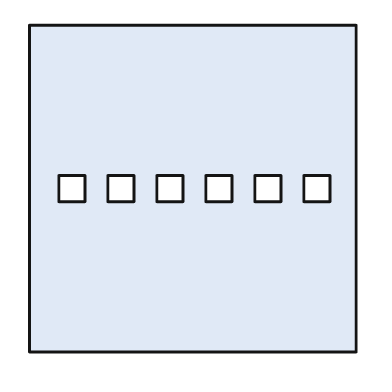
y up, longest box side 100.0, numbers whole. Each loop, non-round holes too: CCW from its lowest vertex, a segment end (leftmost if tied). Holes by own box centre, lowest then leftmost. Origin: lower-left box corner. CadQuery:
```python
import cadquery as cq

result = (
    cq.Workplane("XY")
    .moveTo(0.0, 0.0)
    .lineTo(100.0, 0.0)
    .lineTo(100.0, 100.0)
    .lineTo(0.0, 100.0)
    .close()
    .moveTo(9.0, 46.0)
    .lineTo(17.0, 46.0)
    .lineTo(17.0, 54.0)
    .lineTo(9.0, 54.0)
    .close()
    .moveTo(24.0, 46.0)
    .lineTo(32.0, 46.0)
    .lineTo(32.0, 54.0)
    .lineTo(24.0, 54.0)
    .close()
    .moveTo(39.0, 46.0)
    .lineTo(47.0, 46.0)
    .lineTo(47.0, 54.0)
    .lineTo(39.0, 54.0)
    .close()
    .moveTo(54.0, 46.0)
    .lineTo(62.0, 46.0)
    .lineTo(62.0, 54.0)
    .lineTo(54.0, 54.0)
    .close()
    .moveTo(69.0, 46.0)
    .lineTo(77.0, 46.0)
    .lineTo(77.0, 54.0)
    .lineTo(69.0, 54.0)
    .close()
    .moveTo(84.0, 46.0)
    .lineTo(92.0, 46.0)
    .lineTo(92.0, 54.0)
    .lineTo(84.0, 54.0)
    .close()
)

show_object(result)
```